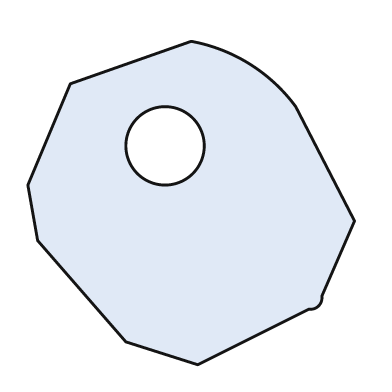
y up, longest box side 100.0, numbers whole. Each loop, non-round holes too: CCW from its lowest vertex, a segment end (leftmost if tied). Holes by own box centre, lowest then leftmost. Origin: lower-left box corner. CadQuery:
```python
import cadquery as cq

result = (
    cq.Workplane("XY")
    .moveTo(52.0, 0.0)
    .lineTo(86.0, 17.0)
    .threePointArc((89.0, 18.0), (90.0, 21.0))
    .lineTo(100.0, 44.0)
    .lineTo(82.0, 79.0)
    .threePointArc((68.0, 92.0), (50.0, 99.0))
    .lineTo(13.0, 86.0)
    .lineTo(0.0, 55.0)
    .lineTo(3.0, 38.0)
    .lineTo(30.0, 7.0)
    .close()
    .moveTo(42.0, 67.0)
    .circle(12.0)
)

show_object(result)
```